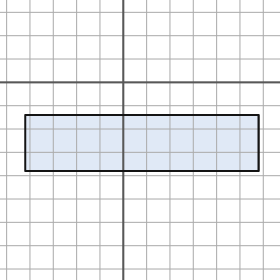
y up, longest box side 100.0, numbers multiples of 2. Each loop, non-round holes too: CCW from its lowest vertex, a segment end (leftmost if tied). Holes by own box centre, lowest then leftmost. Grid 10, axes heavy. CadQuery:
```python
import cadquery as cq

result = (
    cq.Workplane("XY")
    .moveTo(-42.0, -38.0)
    .lineTo(58.0, -38.0)
    .lineTo(58.0, -14.0)
    .lineTo(-42.0, -14.0)
    .close()
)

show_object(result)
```